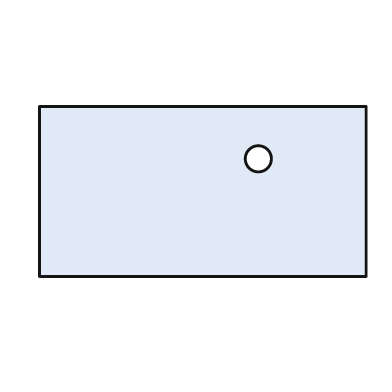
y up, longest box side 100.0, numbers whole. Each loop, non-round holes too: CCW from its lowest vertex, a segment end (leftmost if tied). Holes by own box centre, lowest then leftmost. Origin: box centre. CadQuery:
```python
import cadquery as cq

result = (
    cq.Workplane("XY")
    .moveTo(-50.0, -26.0)
    .lineTo(50.0, -26.0)
    .lineTo(50.0, 26.0)
    .lineTo(-50.0, 26.0)
    .close()
    .moveTo(17.0, 10.0)
    .circle(4.0)
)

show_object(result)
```